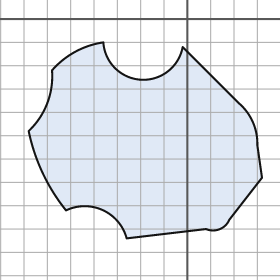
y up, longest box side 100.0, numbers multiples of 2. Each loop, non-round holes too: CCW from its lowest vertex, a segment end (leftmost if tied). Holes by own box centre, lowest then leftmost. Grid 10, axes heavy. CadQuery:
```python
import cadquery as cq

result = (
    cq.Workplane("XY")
    .moveTo(-26.0, -94.0)
    .lineTo(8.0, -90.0)
    .threePointArc((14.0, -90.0), (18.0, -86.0))
    .lineTo(32.0, -68.0)
    .lineTo(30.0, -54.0)
    .threePointArc((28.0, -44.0), (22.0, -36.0))
    .lineTo(-2.0, -12.0)
    .threePointArc((-20.0, -26.0), (-36.0, -10.0))
    .threePointArc((-48.0, -14.0), (-58.0, -22.0))
    .threePointArc((-60.0, -36.0), (-68.0, -48.0))
    .threePointArc((-62.0, -66.0), (-52.0, -82.0))
    .threePointArc((-36.0, -82.0), (-26.0, -94.0))
    .close()
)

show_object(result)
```